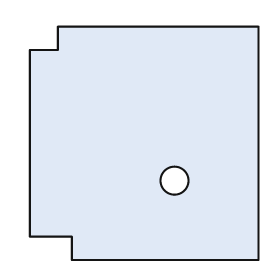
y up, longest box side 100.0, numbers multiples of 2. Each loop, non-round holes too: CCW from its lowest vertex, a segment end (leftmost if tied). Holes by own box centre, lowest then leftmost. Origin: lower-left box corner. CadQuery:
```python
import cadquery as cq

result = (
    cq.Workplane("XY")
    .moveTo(18.0, 0.0)
    .lineTo(98.0, 0.0)
    .lineTo(98.0, 100.0)
    .lineTo(12.0, 100.0)
    .lineTo(12.0, 90.0)
    .lineTo(0.0, 90.0)
    .lineTo(0.0, 10.0)
    .lineTo(18.0, 10.0)
    .close()
    .moveTo(62.0, 34.0)
    .circle(6.0)
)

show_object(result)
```